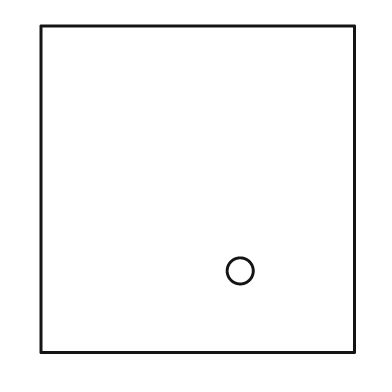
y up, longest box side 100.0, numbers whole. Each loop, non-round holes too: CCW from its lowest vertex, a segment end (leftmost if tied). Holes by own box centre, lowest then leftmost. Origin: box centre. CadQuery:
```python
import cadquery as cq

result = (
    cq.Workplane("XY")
    .moveTo(-48.0, -50.0)
    .lineTo(48.0, -50.0)
    .lineTo(48.0, 50.0)
    .lineTo(-48.0, 50.0)
    .close()
    .moveTo(13.0, -25.0)
    .circle(4.0)
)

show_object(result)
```